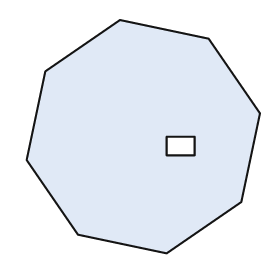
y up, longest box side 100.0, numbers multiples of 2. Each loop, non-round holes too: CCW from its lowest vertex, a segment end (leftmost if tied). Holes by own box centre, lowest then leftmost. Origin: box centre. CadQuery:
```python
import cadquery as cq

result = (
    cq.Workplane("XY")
    .moveTo(10.0, -50.0)
    .lineTo(42.0, -28.0)
    .lineTo(50.0, 10.0)
    .lineTo(28.0, 42.0)
    .lineTo(-10.0, 50.0)
    .lineTo(-42.0, 28.0)
    .lineTo(-50.0, -10.0)
    .lineTo(-28.0, -42.0)
    .close()
    .moveTo(10.0, -8.0)
    .lineTo(22.0, -8.0)
    .lineTo(22.0, 0.0)
    .lineTo(10.0, 0.0)
    .close()
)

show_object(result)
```